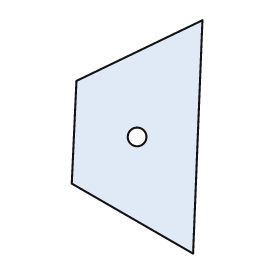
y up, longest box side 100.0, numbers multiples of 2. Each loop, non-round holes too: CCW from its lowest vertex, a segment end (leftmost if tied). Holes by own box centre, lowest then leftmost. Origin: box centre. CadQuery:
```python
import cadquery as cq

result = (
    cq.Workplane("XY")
    .moveTo(24.0, -50.0)
    .lineTo(28.0, 50.0)
    .lineTo(-26.0, 24.0)
    .lineTo(-28.0, -20.0)
    .close()
    .moveTo(0.0, 0.0)
    .circle(4.0)
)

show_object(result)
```